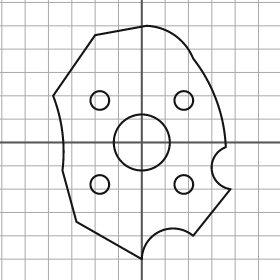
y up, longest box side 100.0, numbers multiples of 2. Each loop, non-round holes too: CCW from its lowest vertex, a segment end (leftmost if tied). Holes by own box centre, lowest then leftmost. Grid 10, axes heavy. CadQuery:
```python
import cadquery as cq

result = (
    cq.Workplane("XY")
    .moveTo(0.0, -50.0)
    .threePointArc((8.0, -38.0), (22.0, -40.0))
    .lineTo(38.0, -20.0)
    .threePointArc((30.0, -12.0), (36.0, -2.0))
    .threePointArc((32.0, 18.0), (22.0, 36.0))
    .threePointArc((14.0, 46.0), (2.0, 50.0))
    .lineTo(-20.0, 46.0)
    .lineTo(-38.0, 20.0)
    .threePointArc((-34.0, 4.0), (-34.0, -12.0))
    .lineTo(-28.0, -34.0)
    .close()
    .moveTo(-18.0, -18.0)
    .circle(4.0)
    .moveTo(18.0, -18.0)
    .circle(4.0)
    .moveTo(0.0, 0.0)
    .circle(12.0)
    .moveTo(-18.0, 18.0)
    .circle(4.0)
    .moveTo(18.0, 18.0)
    .circle(4.0)
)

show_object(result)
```